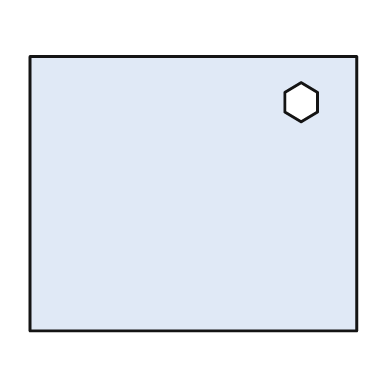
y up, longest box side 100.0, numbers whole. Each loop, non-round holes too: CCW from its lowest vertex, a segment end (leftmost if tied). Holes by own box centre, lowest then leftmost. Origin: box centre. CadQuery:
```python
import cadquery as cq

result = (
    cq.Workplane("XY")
    .moveTo(-50.0, -42.0)
    .lineTo(50.0, -42.0)
    .lineTo(50.0, 42.0)
    .lineTo(-50.0, 42.0)
    .close()
    .moveTo(33.0, 22.0)
    .lineTo(38.0, 25.0)
    .lineTo(38.0, 31.0)
    .lineTo(33.0, 34.0)
    .lineTo(28.0, 31.0)
    .lineTo(28.0, 25.0)
    .close()
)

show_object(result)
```